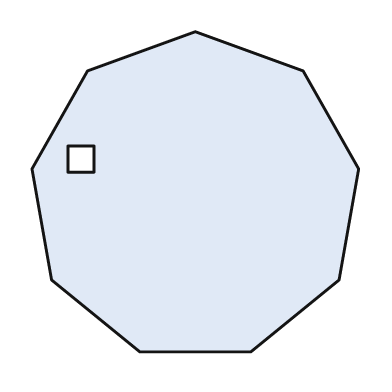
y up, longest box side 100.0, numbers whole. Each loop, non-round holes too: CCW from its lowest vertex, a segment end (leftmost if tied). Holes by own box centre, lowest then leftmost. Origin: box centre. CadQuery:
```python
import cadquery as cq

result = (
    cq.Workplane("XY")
    .moveTo(-17.0, -49.0)
    .lineTo(17.0, -49.0)
    .lineTo(44.0, -27.0)
    .lineTo(50.0, 7.0)
    .lineTo(33.0, 37.0)
    .lineTo(0.0, 49.0)
    .lineTo(-33.0, 37.0)
    .lineTo(-50.0, 7.0)
    .lineTo(-44.0, -27.0)
    .close()
    .moveTo(-39.0, 6.0)
    .lineTo(-31.0, 6.0)
    .lineTo(-31.0, 14.0)
    .lineTo(-39.0, 14.0)
    .close()
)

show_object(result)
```